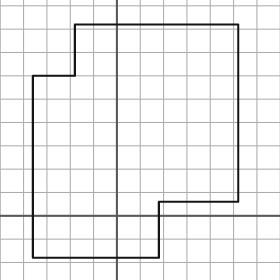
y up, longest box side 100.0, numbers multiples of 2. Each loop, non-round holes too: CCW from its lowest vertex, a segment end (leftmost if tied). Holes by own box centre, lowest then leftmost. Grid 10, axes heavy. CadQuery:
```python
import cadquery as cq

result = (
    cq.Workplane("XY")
    .moveTo(-36.0, -18.0)
    .lineTo(18.0, -18.0)
    .lineTo(18.0, 6.0)
    .lineTo(52.0, 6.0)
    .lineTo(52.0, 82.0)
    .lineTo(-18.0, 82.0)
    .lineTo(-18.0, 60.0)
    .lineTo(-36.0, 60.0)
    .close()
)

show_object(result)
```